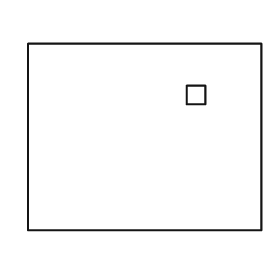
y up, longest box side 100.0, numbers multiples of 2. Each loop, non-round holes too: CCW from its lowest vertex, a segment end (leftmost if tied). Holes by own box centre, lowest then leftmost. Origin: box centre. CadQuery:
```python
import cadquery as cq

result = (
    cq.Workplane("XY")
    .moveTo(-50.0, -40.0)
    .lineTo(50.0, -40.0)
    .lineTo(50.0, 40.0)
    .lineTo(-50.0, 40.0)
    .close()
    .moveTo(18.0, 14.0)
    .lineTo(26.0, 14.0)
    .lineTo(26.0, 22.0)
    .lineTo(18.0, 22.0)
    .close()
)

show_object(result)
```